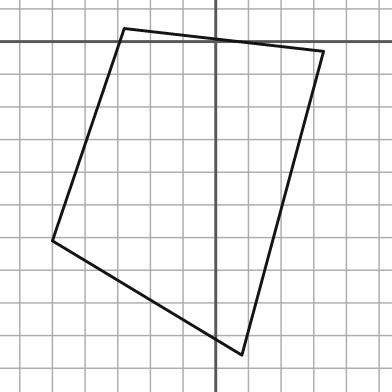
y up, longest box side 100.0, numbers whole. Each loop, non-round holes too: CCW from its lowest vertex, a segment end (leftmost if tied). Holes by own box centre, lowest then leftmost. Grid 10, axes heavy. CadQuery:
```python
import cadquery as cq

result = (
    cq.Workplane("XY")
    .moveTo(8.0, -96.0)
    .lineTo(33.0, -3.0)
    .lineTo(-28.0, 4.0)
    .lineTo(-50.0, -61.0)
    .close()
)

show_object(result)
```